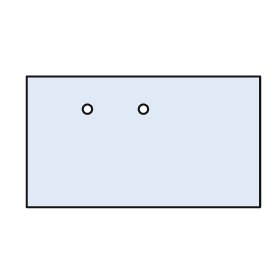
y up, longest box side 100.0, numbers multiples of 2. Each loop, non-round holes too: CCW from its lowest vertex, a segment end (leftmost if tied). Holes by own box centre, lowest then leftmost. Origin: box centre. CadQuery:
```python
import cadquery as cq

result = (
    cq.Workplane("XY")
    .moveTo(-50.0, -28.0)
    .lineTo(50.0, -28.0)
    .lineTo(50.0, 28.0)
    .lineTo(-50.0, 28.0)
    .close()
    .moveTo(-24.0, 14.0)
    .circle(2.0)
    .moveTo(0.0, 14.0)
    .circle(2.0)
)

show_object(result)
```